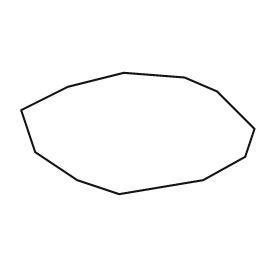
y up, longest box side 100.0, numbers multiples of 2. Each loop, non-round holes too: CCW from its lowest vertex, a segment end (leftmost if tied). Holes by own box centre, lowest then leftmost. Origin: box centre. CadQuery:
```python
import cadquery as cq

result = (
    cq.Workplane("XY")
    .moveTo(-8.0, -26.0)
    .lineTo(28.0, -20.0)
    .lineTo(46.0, -10.0)
    .lineTo(50.0, 2.0)
    .lineTo(34.0, 18.0)
    .lineTo(20.0, 24.0)
    .lineTo(-6.0, 26.0)
    .lineTo(-30.0, 20.0)
    .lineTo(-50.0, 10.0)
    .lineTo(-44.0, -8.0)
    .lineTo(-26.0, -20.0)
    .close()
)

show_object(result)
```